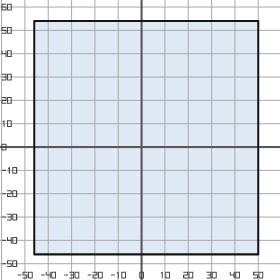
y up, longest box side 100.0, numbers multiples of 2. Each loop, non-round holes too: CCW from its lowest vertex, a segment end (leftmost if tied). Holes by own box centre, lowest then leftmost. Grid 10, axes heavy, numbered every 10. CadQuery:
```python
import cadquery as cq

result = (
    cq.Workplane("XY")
    .moveTo(-46.0, -46.0)
    .lineTo(50.0, -46.0)
    .lineTo(50.0, 54.0)
    .lineTo(-46.0, 54.0)
    .close()
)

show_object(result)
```